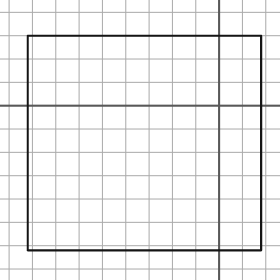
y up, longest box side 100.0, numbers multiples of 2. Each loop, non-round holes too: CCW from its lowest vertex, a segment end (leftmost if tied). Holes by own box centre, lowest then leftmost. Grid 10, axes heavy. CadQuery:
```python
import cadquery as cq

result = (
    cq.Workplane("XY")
    .moveTo(-82.0, -62.0)
    .lineTo(18.0, -62.0)
    .lineTo(18.0, 30.0)
    .lineTo(-82.0, 30.0)
    .close()
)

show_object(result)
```